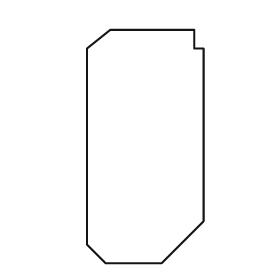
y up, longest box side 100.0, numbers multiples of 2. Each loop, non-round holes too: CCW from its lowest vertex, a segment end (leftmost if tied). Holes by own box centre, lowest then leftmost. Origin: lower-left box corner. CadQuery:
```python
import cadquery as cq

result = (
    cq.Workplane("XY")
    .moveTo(8.0, 0.0)
    .lineTo(32.0, 0.0)
    .lineTo(50.0, 18.0)
    .lineTo(50.0, 92.0)
    .lineTo(46.0, 92.0)
    .lineTo(46.0, 100.0)
    .lineTo(10.0, 100.0)
    .lineTo(0.0, 92.0)
    .lineTo(0.0, 8.0)
    .close()
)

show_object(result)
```